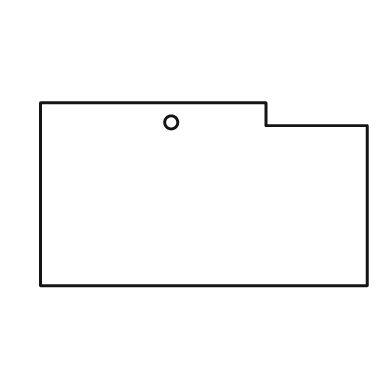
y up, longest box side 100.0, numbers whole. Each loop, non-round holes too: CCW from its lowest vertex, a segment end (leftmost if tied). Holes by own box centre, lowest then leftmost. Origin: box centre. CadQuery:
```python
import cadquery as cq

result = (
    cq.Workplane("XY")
    .moveTo(-50.0, -28.0)
    .lineTo(50.0, -28.0)
    .lineTo(50.0, 21.0)
    .lineTo(19.0, 21.0)
    .lineTo(19.0, 28.0)
    .lineTo(-50.0, 28.0)
    .close()
    .moveTo(-10.0, 22.0)
    .circle(2.0)
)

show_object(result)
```